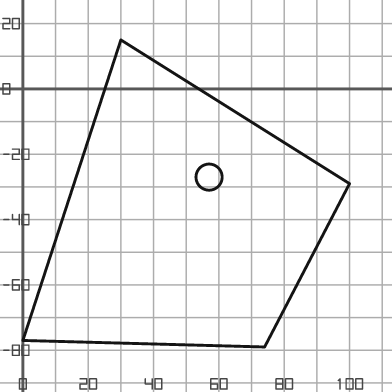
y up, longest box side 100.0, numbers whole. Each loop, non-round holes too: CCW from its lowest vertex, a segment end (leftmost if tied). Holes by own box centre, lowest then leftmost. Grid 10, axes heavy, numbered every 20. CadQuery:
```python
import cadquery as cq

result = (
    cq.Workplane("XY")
    .moveTo(74.0, -79.0)
    .lineTo(100.0, -29.0)
    .lineTo(30.0, 15.0)
    .lineTo(0.0, -77.0)
    .close()
    .moveTo(57.0, -27.0)
    .circle(4.0)
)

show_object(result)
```